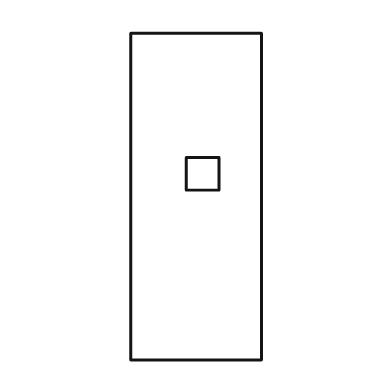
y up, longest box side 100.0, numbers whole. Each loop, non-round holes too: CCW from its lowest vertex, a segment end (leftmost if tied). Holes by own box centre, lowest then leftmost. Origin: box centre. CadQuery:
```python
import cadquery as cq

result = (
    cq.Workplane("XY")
    .moveTo(-20.0, -50.0)
    .lineTo(20.0, -50.0)
    .lineTo(20.0, 50.0)
    .lineTo(-20.0, 50.0)
    .close()
    .moveTo(-3.0, 2.0)
    .lineTo(7.0, 2.0)
    .lineTo(7.0, 12.0)
    .lineTo(-3.0, 12.0)
    .close()
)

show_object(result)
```